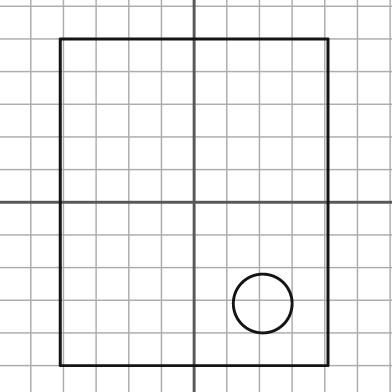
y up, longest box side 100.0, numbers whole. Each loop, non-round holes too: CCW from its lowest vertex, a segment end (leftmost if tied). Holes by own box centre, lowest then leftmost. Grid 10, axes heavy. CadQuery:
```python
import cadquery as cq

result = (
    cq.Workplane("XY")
    .moveTo(-41.0, -50.0)
    .lineTo(41.0, -50.0)
    .lineTo(41.0, 50.0)
    .lineTo(-41.0, 50.0)
    .close()
    .moveTo(21.0, -31.0)
    .circle(9.0)
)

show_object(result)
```